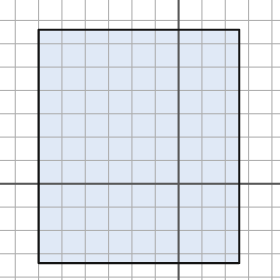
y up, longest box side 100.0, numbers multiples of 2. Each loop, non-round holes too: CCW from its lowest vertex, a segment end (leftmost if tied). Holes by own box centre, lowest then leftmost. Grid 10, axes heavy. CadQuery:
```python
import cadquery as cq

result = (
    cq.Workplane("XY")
    .moveTo(-60.0, -34.0)
    .lineTo(26.0, -34.0)
    .lineTo(26.0, 66.0)
    .lineTo(-60.0, 66.0)
    .close()
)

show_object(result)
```